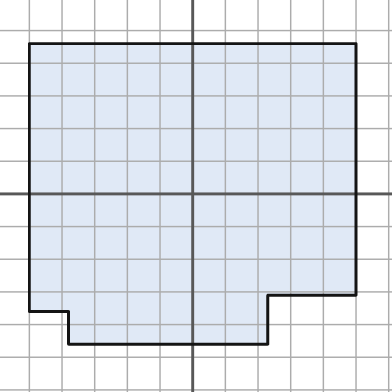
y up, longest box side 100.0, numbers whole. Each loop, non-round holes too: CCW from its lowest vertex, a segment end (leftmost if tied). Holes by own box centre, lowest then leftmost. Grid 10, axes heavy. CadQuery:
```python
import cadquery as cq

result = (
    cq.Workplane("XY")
    .moveTo(-38.0, -46.0)
    .lineTo(23.0, -46.0)
    .lineTo(23.0, -31.0)
    .lineTo(50.0, -31.0)
    .lineTo(50.0, 46.0)
    .lineTo(-50.0, 46.0)
    .lineTo(-50.0, -36.0)
    .lineTo(-38.0, -36.0)
    .close()
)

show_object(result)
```